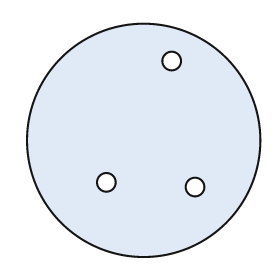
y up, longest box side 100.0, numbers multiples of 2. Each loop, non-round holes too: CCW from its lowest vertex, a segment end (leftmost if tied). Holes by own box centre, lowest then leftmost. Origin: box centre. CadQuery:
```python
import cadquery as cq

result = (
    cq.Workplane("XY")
    .moveTo(0.0, 0.0)
    .circle(50.0)
    .moveTo(22.0, -20.0)
    .circle(4.0)
    .moveTo(-16.0, -18.0)
    .circle(4.0)
    .moveTo(12.0, 34.0)
    .circle(4.0)
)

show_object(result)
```